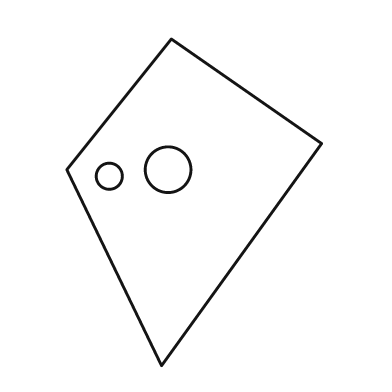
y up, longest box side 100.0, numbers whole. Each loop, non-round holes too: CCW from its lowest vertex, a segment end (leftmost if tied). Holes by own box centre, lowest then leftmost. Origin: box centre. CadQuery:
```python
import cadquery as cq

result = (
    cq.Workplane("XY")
    .moveTo(-10.0, -50.0)
    .lineTo(39.0, 18.0)
    .lineTo(-7.0, 50.0)
    .lineTo(-39.0, 10.0)
    .close()
    .moveTo(-26.0, 8.0)
    .circle(4.0)
    .moveTo(-8.0, 10.0)
    .circle(7.0)
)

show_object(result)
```